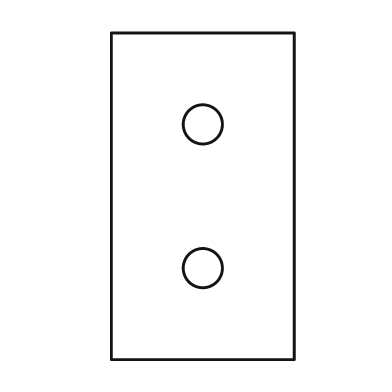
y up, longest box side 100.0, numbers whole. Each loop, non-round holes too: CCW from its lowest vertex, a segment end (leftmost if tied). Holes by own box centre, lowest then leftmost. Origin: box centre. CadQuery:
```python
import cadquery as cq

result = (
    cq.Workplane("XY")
    .moveTo(-28.0, -50.0)
    .lineTo(28.0, -50.0)
    .lineTo(28.0, 50.0)
    .lineTo(-28.0, 50.0)
    .close()
    .moveTo(0.0, -22.0)
    .circle(6.0)
    .moveTo(0.0, 22.0)
    .circle(6.0)
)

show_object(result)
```